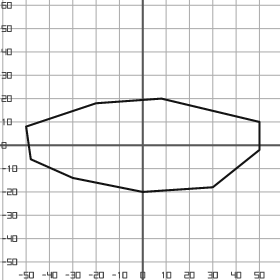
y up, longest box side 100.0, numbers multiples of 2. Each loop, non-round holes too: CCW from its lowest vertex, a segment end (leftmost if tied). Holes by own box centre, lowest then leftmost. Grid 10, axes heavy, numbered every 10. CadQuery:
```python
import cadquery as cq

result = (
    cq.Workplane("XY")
    .moveTo(0.0, -20.0)
    .lineTo(30.0, -18.0)
    .lineTo(50.0, -2.0)
    .lineTo(50.0, 10.0)
    .lineTo(8.0, 20.0)
    .lineTo(-20.0, 18.0)
    .lineTo(-50.0, 8.0)
    .lineTo(-48.0, -6.0)
    .lineTo(-30.0, -14.0)
    .close()
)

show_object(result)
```